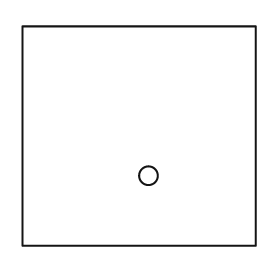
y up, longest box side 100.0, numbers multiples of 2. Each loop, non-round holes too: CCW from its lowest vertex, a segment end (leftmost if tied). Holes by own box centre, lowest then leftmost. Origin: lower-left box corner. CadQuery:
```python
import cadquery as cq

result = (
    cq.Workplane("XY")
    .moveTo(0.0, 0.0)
    .lineTo(100.0, 0.0)
    .lineTo(100.0, 94.0)
    .lineTo(0.0, 94.0)
    .close()
    .moveTo(54.0, 30.0)
    .circle(4.0)
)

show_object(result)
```